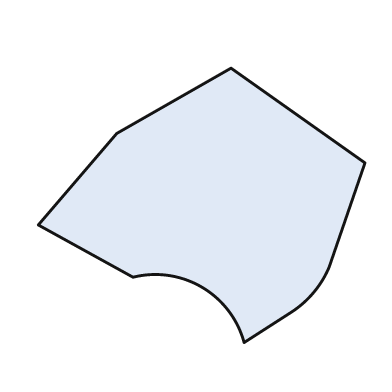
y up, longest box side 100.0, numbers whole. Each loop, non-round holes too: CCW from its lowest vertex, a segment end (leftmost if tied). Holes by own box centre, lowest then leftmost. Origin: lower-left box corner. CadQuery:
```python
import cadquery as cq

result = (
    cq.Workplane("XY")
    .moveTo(63.0, 0.0)
    .lineTo(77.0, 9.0)
    .threePointArc((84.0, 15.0), (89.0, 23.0))
    .lineTo(100.0, 55.0)
    .lineTo(59.0, 84.0)
    .lineTo(24.0, 64.0)
    .lineTo(0.0, 36.0)
    .lineTo(29.0, 20.0)
    .threePointArc((50.0, 17.0), (63.0, 0.0))
    .close()
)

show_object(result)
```